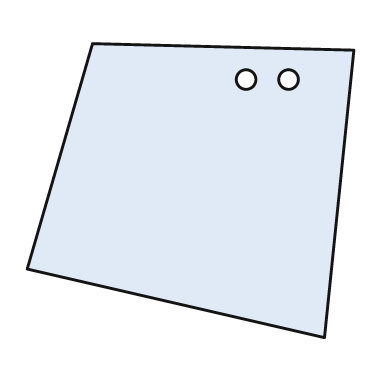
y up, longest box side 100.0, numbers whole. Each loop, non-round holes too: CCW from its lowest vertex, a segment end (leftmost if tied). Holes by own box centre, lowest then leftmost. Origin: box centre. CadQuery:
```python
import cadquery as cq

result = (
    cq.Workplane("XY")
    .moveTo(41.0, -45.0)
    .lineTo(50.0, 43.0)
    .lineTo(-30.0, 45.0)
    .lineTo(-50.0, -24.0)
    .close()
    .moveTo(17.0, 34.0)
    .circle(3.0)
    .moveTo(30.0, 34.0)
    .circle(3.0)
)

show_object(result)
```